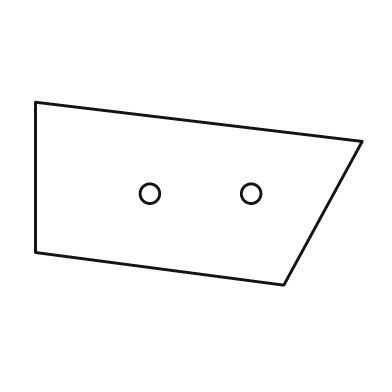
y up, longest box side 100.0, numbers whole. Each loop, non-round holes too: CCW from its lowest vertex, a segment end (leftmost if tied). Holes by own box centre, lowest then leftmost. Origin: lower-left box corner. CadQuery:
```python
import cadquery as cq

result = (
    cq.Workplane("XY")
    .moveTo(76.0, 0.0)
    .lineTo(100.0, 44.0)
    .lineTo(0.0, 56.0)
    .lineTo(0.0, 10.0)
    .close()
    .moveTo(35.0, 28.0)
    .circle(3.0)
    .moveTo(66.0, 28.0)
    .circle(3.0)
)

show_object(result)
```